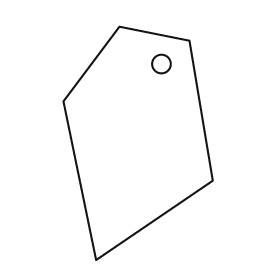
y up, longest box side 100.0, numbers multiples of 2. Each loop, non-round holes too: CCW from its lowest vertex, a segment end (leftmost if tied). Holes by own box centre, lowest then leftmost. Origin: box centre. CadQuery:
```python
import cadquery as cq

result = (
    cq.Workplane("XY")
    .moveTo(-18.0, -50.0)
    .lineTo(32.0, -16.0)
    .lineTo(22.0, 44.0)
    .lineTo(-8.0, 50.0)
    .lineTo(-32.0, 18.0)
    .close()
    .moveTo(10.0, 34.0)
    .circle(4.0)
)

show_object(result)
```